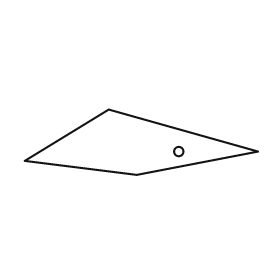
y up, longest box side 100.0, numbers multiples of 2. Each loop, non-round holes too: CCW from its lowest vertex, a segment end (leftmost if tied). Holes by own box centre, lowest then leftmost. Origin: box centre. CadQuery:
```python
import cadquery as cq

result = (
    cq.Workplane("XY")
    .moveTo(-2.0, -14.0)
    .lineTo(50.0, -4.0)
    .lineTo(-14.0, 14.0)
    .lineTo(-50.0, -8.0)
    .close()
    .moveTo(16.0, -4.0)
    .circle(2.0)
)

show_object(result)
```